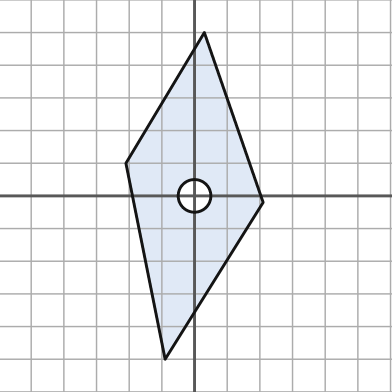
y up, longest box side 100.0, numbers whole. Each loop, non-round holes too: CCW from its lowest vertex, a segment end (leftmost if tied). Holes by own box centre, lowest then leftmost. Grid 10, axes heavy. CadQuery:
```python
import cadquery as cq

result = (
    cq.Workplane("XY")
    .moveTo(-9.0, -50.0)
    .lineTo(21.0, -2.0)
    .lineTo(3.0, 50.0)
    .lineTo(-21.0, 10.0)
    .close()
    .moveTo(0.0, 0.0)
    .circle(5.0)
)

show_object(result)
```